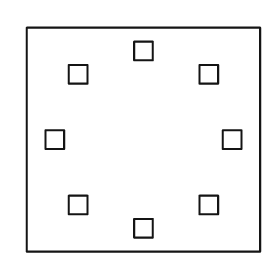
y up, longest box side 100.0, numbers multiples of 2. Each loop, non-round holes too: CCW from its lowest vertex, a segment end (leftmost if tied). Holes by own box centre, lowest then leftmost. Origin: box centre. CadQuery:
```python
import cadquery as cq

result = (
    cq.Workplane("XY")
    .moveTo(-50.0, -48.0)
    .lineTo(50.0, -48.0)
    .lineTo(50.0, 48.0)
    .lineTo(-50.0, 48.0)
    .close()
    .moveTo(-4.0, -42.0)
    .lineTo(4.0, -42.0)
    .lineTo(4.0, -34.0)
    .lineTo(-4.0, -34.0)
    .close()
    .moveTo(-32.0, -32.0)
    .lineTo(-24.0, -32.0)
    .lineTo(-24.0, -24.0)
    .lineTo(-32.0, -24.0)
    .close()
    .moveTo(24.0, -32.0)
    .lineTo(32.0, -32.0)
    .lineTo(32.0, -24.0)
    .lineTo(24.0, -24.0)
    .close()
    .moveTo(-42.0, -4.0)
    .lineTo(-34.0, -4.0)
    .lineTo(-34.0, 4.0)
    .lineTo(-42.0, 4.0)
    .close()
    .moveTo(34.0, -4.0)
    .lineTo(42.0, -4.0)
    .lineTo(42.0, 4.0)
    .lineTo(34.0, 4.0)
    .close()
    .moveTo(-32.0, 24.0)
    .lineTo(-24.0, 24.0)
    .lineTo(-24.0, 32.0)
    .lineTo(-32.0, 32.0)
    .close()
    .moveTo(24.0, 24.0)
    .lineTo(32.0, 24.0)
    .lineTo(32.0, 32.0)
    .lineTo(24.0, 32.0)
    .close()
    .moveTo(-4.0, 34.0)
    .lineTo(4.0, 34.0)
    .lineTo(4.0, 42.0)
    .lineTo(-4.0, 42.0)
    .close()
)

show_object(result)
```